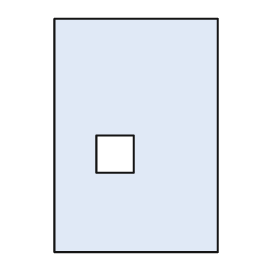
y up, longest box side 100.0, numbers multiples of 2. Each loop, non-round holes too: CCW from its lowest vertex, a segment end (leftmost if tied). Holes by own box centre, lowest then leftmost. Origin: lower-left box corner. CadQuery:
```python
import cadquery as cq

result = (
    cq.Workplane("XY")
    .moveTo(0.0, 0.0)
    .lineTo(70.0, 0.0)
    .lineTo(70.0, 100.0)
    .lineTo(0.0, 100.0)
    .close()
    .moveTo(18.0, 34.0)
    .lineTo(34.0, 34.0)
    .lineTo(34.0, 50.0)
    .lineTo(18.0, 50.0)
    .close()
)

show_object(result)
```